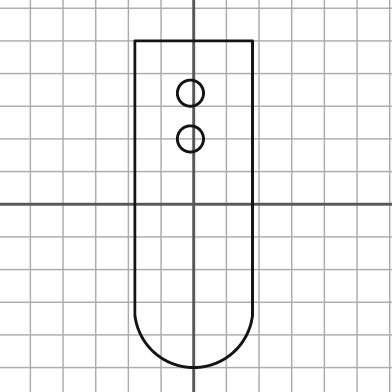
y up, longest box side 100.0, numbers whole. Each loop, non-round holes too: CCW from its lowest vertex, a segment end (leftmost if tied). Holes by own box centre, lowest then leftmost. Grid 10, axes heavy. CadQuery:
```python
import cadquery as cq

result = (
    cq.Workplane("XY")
    .moveTo(-18.0, -34.0)
    .threePointArc((0.0, -50.0), (18.0, -34.0))
    .lineTo(18.0, 50.0)
    .lineTo(-18.0, 50.0)
    .close()
    .moveTo(-1.0, 20.0)
    .circle(4.0)
    .moveTo(-1.0, 34.0)
    .circle(4.0)
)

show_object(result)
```